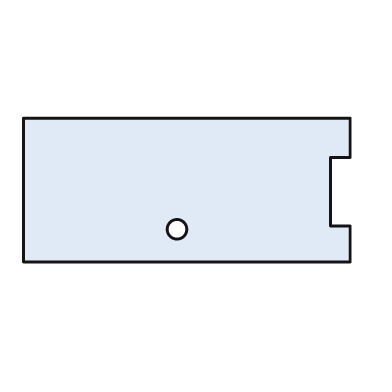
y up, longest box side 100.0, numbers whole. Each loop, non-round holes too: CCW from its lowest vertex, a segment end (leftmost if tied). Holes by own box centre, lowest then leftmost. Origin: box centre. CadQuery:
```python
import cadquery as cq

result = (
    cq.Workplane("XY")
    .moveTo(-50.0, -22.0)
    .lineTo(50.0, -22.0)
    .lineTo(50.0, -11.0)
    .lineTo(44.0, -11.0)
    .lineTo(44.0, 10.0)
    .lineTo(50.0, 10.0)
    .lineTo(50.0, 22.0)
    .lineTo(-50.0, 22.0)
    .close()
    .moveTo(-3.0, -12.0)
    .circle(3.0)
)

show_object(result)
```